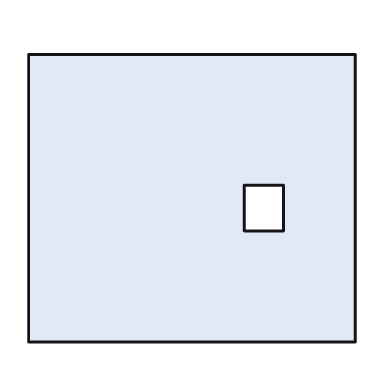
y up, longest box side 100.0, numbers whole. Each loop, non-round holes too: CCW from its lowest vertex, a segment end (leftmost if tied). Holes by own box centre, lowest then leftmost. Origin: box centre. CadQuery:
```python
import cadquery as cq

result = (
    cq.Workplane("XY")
    .moveTo(-50.0, -44.0)
    .lineTo(50.0, -44.0)
    .lineTo(50.0, 44.0)
    .lineTo(-50.0, 44.0)
    .close()
    .moveTo(16.0, -10.0)
    .lineTo(28.0, -10.0)
    .lineTo(28.0, 4.0)
    .lineTo(16.0, 4.0)
    .close()
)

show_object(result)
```